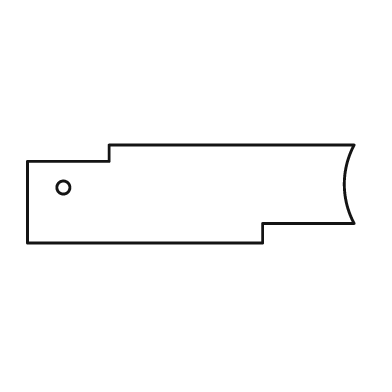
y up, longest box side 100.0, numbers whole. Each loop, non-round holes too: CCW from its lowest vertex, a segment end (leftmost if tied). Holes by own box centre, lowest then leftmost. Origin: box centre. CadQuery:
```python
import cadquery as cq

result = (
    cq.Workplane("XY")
    .moveTo(-50.0, -15.0)
    .lineTo(22.0, -15.0)
    .lineTo(22.0, -9.0)
    .lineTo(50.0, -9.0)
    .threePointArc((47.0, 3.0), (50.0, 15.0))
    .lineTo(-25.0, 15.0)
    .lineTo(-25.0, 10.0)
    .lineTo(-50.0, 10.0)
    .close()
    .moveTo(-39.0, 2.0)
    .circle(2.0)
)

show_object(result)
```